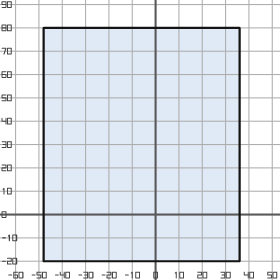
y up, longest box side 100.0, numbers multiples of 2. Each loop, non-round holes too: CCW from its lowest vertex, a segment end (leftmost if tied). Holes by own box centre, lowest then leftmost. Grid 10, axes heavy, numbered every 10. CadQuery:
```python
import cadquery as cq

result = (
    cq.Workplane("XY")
    .moveTo(-48.0, -20.0)
    .lineTo(36.0, -20.0)
    .lineTo(36.0, 80.0)
    .lineTo(-48.0, 80.0)
    .close()
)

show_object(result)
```